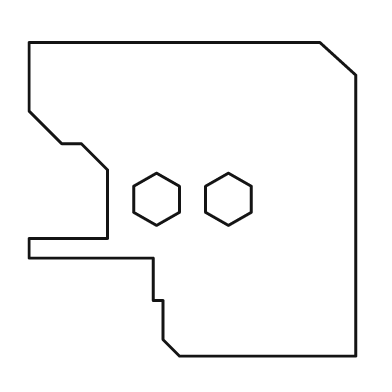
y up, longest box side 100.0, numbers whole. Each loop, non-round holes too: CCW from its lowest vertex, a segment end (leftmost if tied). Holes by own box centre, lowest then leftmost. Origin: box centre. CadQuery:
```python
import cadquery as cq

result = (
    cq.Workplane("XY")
    .moveTo(-4.0, -48.0)
    .lineTo(50.0, -48.0)
    .lineTo(50.0, 38.0)
    .lineTo(39.0, 48.0)
    .lineTo(-50.0, 48.0)
    .lineTo(-50.0, 27.0)
    .lineTo(-40.0, 17.0)
    .lineTo(-34.0, 17.0)
    .lineTo(-26.0, 9.0)
    .lineTo(-26.0, -12.0)
    .lineTo(-50.0, -12.0)
    .lineTo(-50.0, -18.0)
    .lineTo(-12.0, -18.0)
    .lineTo(-12.0, -31.0)
    .lineTo(-9.0, -31.0)
    .lineTo(-9.0, -43.0)
    .close()
    .moveTo(-11.0, -8.0)
    .lineTo(-4.0, -4.0)
    .lineTo(-4.0, 4.0)
    .lineTo(-11.0, 8.0)
    .lineTo(-18.0, 4.0)
    .lineTo(-18.0, -4.0)
    .close()
    .moveTo(11.0, -8.0)
    .lineTo(18.0, -4.0)
    .lineTo(18.0, 4.0)
    .lineTo(11.0, 8.0)
    .lineTo(4.0, 4.0)
    .lineTo(4.0, -4.0)
    .close()
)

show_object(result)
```